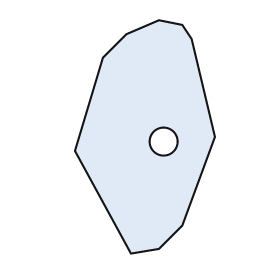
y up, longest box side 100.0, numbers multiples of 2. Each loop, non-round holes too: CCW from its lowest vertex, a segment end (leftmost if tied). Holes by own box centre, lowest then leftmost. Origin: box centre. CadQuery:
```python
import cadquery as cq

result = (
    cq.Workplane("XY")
    .moveTo(-6.0, -50.0)
    .lineTo(6.0, -48.0)
    .lineTo(16.0, -38.0)
    .lineTo(30.0, 0.0)
    .lineTo(20.0, 42.0)
    .lineTo(16.0, 48.0)
    .lineTo(6.0, 50.0)
    .lineTo(-8.0, 44.0)
    .lineTo(-18.0, 34.0)
    .lineTo(-30.0, -6.0)
    .close()
    .moveTo(8.0, -2.0)
    .circle(6.0)
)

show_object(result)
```